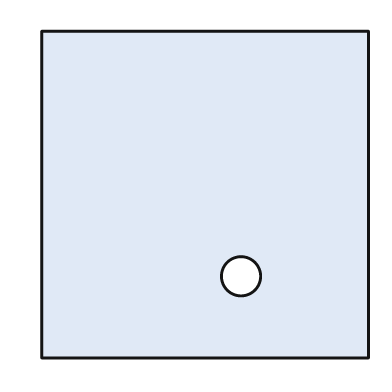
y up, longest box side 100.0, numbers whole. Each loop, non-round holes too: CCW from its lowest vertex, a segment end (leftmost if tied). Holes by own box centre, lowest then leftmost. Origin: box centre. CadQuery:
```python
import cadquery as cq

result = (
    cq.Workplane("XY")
    .moveTo(-50.0, -50.0)
    .lineTo(50.0, -50.0)
    .lineTo(50.0, 50.0)
    .lineTo(-50.0, 50.0)
    .close()
    .moveTo(11.0, -25.0)
    .circle(6.0)
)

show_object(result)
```